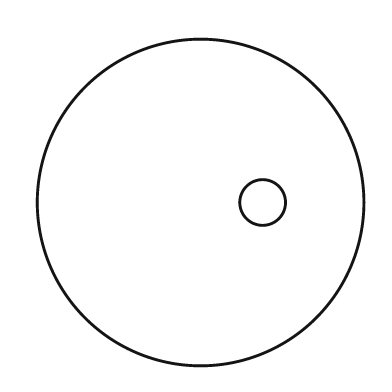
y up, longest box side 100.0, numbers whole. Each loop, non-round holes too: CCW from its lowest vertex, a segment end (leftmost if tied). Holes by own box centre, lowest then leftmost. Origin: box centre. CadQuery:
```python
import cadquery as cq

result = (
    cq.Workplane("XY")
    .moveTo(0.0, 0.0)
    .circle(50.0)
    .moveTo(19.0, 0.0)
    .circle(7.0)
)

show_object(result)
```